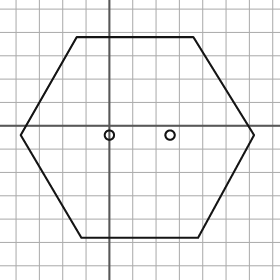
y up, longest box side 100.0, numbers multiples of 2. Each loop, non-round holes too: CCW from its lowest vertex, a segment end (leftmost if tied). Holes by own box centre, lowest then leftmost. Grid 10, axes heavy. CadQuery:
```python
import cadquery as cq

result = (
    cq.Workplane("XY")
    .moveTo(-12.0, -48.0)
    .lineTo(38.0, -48.0)
    .lineTo(62.0, -4.0)
    .lineTo(36.0, 38.0)
    .lineTo(-14.0, 38.0)
    .lineTo(-38.0, -4.0)
    .close()
    .moveTo(0.0, -4.0)
    .circle(2.0)
    .moveTo(26.0, -4.0)
    .circle(2.0)
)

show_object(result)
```